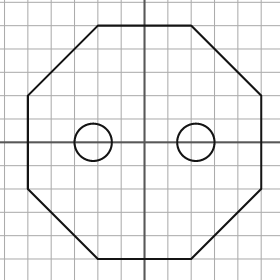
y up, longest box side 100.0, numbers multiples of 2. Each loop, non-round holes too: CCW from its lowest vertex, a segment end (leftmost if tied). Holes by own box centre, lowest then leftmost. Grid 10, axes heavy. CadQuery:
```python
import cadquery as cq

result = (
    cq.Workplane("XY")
    .moveTo(-20.0, -50.0)
    .lineTo(20.0, -50.0)
    .lineTo(50.0, -20.0)
    .lineTo(50.0, 20.0)
    .lineTo(20.0, 50.0)
    .lineTo(-20.0, 50.0)
    .lineTo(-50.0, 20.0)
    .lineTo(-50.0, -20.0)
    .close()
    .moveTo(-22.0, 0.0)
    .circle(8.0)
    .moveTo(22.0, 0.0)
    .circle(8.0)
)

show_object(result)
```